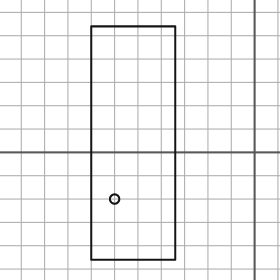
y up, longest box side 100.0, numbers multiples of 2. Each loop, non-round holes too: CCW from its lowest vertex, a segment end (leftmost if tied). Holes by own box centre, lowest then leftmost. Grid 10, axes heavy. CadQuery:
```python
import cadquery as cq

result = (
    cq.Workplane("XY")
    .moveTo(-70.0, -46.0)
    .lineTo(-34.0, -46.0)
    .lineTo(-34.0, 54.0)
    .lineTo(-70.0, 54.0)
    .close()
    .moveTo(-60.0, -20.0)
    .circle(2.0)
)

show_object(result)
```